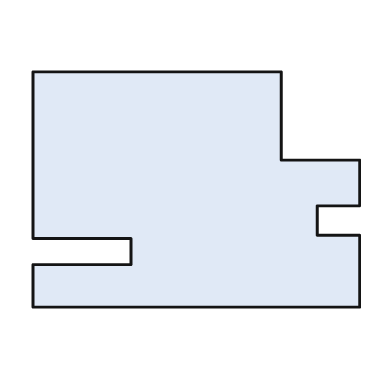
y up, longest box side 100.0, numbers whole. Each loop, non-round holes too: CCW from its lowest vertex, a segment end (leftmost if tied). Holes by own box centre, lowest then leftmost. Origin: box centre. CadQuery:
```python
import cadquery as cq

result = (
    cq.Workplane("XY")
    .moveTo(-50.0, -36.0)
    .lineTo(50.0, -36.0)
    .lineTo(50.0, -14.0)
    .lineTo(37.0, -14.0)
    .lineTo(37.0, -5.0)
    .lineTo(50.0, -5.0)
    .lineTo(50.0, 9.0)
    .lineTo(26.0, 9.0)
    .lineTo(26.0, 36.0)
    .lineTo(-50.0, 36.0)
    .lineTo(-50.0, -15.0)
    .lineTo(-20.0, -15.0)
    .lineTo(-20.0, -23.0)
    .lineTo(-50.0, -23.0)
    .close()
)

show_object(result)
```